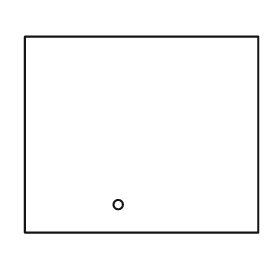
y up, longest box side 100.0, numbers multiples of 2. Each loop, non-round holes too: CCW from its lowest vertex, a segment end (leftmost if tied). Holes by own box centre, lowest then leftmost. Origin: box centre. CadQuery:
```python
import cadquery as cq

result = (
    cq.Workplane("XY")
    .moveTo(-50.0, -42.0)
    .lineTo(50.0, -42.0)
    .lineTo(50.0, 42.0)
    .lineTo(-50.0, 42.0)
    .close()
    .moveTo(-10.0, -30.0)
    .circle(2.0)
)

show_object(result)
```